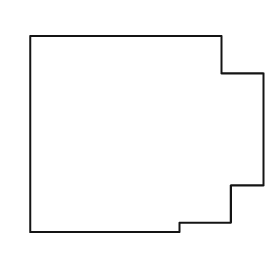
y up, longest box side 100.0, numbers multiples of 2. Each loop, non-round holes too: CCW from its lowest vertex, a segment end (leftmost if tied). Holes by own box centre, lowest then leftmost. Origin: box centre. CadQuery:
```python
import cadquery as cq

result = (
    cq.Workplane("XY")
    .moveTo(-50.0, -42.0)
    .lineTo(14.0, -42.0)
    .lineTo(14.0, -38.0)
    .lineTo(36.0, -38.0)
    .lineTo(36.0, -22.0)
    .lineTo(50.0, -22.0)
    .lineTo(50.0, 26.0)
    .lineTo(32.0, 26.0)
    .lineTo(32.0, 42.0)
    .lineTo(-50.0, 42.0)
    .close()
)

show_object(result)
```